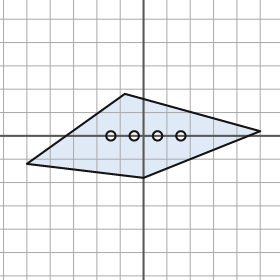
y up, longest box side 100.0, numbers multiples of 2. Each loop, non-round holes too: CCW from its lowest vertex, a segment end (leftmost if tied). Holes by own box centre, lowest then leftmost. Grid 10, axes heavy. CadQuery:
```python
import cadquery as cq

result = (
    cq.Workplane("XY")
    .moveTo(0.0, -18.0)
    .lineTo(50.0, 2.0)
    .lineTo(-8.0, 18.0)
    .lineTo(-50.0, -12.0)
    .close()
    .moveTo(-14.0, 0.0)
    .circle(2.0)
    .moveTo(-4.0, 0.0)
    .circle(2.0)
    .moveTo(6.0, 0.0)
    .circle(2.0)
    .moveTo(16.0, 0.0)
    .circle(2.0)
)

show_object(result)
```